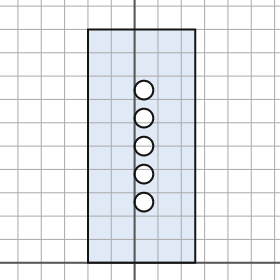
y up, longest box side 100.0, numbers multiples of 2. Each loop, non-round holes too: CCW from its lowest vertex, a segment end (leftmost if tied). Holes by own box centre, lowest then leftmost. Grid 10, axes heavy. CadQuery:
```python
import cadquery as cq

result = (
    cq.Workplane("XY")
    .moveTo(-20.0, 0.0)
    .lineTo(26.0, 0.0)
    .lineTo(26.0, 100.0)
    .lineTo(-20.0, 100.0)
    .close()
    .moveTo(4.0, 26.0)
    .circle(4.0)
    .moveTo(4.0, 38.0)
    .circle(4.0)
    .moveTo(4.0, 50.0)
    .circle(4.0)
    .moveTo(4.0, 62.0)
    .circle(4.0)
    .moveTo(4.0, 74.0)
    .circle(4.0)
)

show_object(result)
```